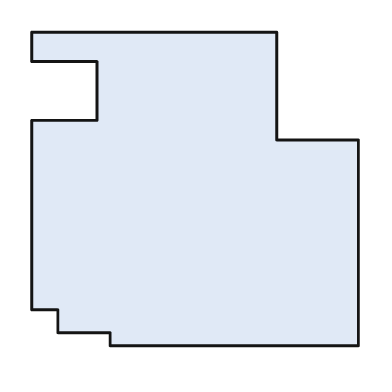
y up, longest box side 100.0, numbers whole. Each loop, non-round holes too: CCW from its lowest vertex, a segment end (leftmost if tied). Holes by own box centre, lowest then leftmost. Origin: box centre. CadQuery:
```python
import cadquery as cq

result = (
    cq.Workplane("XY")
    .moveTo(-26.0, -48.0)
    .lineTo(50.0, -48.0)
    .lineTo(50.0, 15.0)
    .lineTo(25.0, 15.0)
    .lineTo(25.0, 48.0)
    .lineTo(-50.0, 48.0)
    .lineTo(-50.0, 39.0)
    .lineTo(-30.0, 39.0)
    .lineTo(-30.0, 21.0)
    .lineTo(-50.0, 21.0)
    .lineTo(-50.0, -37.0)
    .lineTo(-42.0, -37.0)
    .lineTo(-42.0, -44.0)
    .lineTo(-26.0, -44.0)
    .close()
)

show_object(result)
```